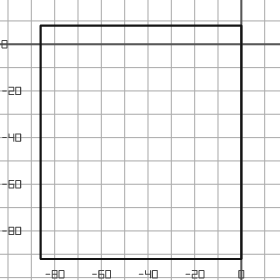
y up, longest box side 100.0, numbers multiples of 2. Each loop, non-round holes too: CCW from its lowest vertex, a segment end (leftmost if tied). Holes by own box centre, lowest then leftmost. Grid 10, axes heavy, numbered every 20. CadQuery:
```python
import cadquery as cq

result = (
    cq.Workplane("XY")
    .moveTo(-86.0, -92.0)
    .lineTo(0.0, -92.0)
    .lineTo(0.0, 8.0)
    .lineTo(-86.0, 8.0)
    .close()
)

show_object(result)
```